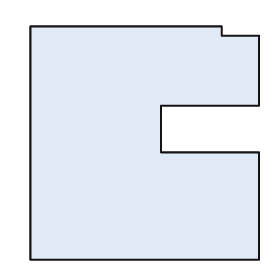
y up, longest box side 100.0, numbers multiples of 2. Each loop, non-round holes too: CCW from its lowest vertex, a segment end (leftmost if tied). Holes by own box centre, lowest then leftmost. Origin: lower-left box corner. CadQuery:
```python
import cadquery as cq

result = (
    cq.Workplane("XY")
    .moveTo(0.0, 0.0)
    .lineTo(98.0, 0.0)
    .lineTo(98.0, 46.0)
    .lineTo(56.0, 46.0)
    .lineTo(56.0, 66.0)
    .lineTo(98.0, 66.0)
    .lineTo(98.0, 96.0)
    .lineTo(82.0, 96.0)
    .lineTo(82.0, 100.0)
    .lineTo(0.0, 100.0)
    .close()
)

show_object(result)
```